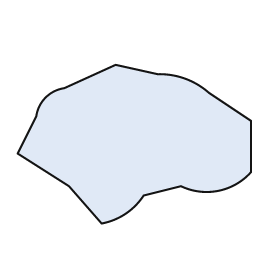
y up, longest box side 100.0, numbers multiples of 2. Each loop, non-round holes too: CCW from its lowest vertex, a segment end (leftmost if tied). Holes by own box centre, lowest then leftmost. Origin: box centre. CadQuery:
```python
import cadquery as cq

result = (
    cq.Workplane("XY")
    .moveTo(-14.0, -34.0)
    .threePointArc((-4.0, -30.0), (4.0, -22.0))
    .lineTo(20.0, -18.0)
    .threePointArc((36.0, -20.0), (50.0, -12.0))
    .lineTo(50.0, 10.0)
    .lineTo(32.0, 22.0)
    .threePointArc((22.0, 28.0), (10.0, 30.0))
    .lineTo(-8.0, 34.0)
    .lineTo(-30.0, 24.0)
    .threePointArc((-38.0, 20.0), (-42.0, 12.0))
    .lineTo(-50.0, -4.0)
    .lineTo(-28.0, -18.0)
    .close()
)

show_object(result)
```